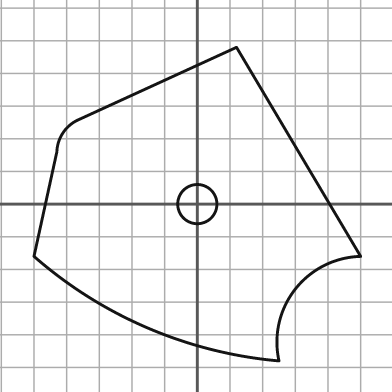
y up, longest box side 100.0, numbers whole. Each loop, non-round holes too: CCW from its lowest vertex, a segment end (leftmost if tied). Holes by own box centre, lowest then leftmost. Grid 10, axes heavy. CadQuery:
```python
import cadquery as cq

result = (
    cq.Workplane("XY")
    .moveTo(25.0, -48.0)
    .threePointArc((30.0, -26.0), (50.0, -16.0))
    .lineTo(12.0, 48.0)
    .lineTo(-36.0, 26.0)
    .threePointArc((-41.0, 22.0), (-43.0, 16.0))
    .lineTo(-50.0, -16.0)
    .threePointArc((-15.0, -38.0), (25.0, -48.0))
    .close()
    .moveTo(0.0, 0.0)
    .circle(6.0)
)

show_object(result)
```